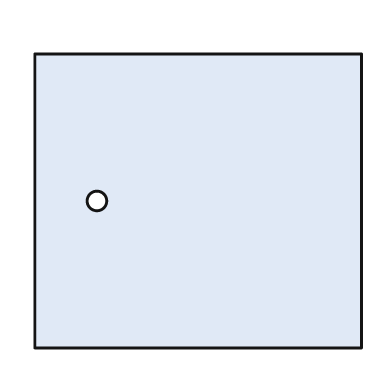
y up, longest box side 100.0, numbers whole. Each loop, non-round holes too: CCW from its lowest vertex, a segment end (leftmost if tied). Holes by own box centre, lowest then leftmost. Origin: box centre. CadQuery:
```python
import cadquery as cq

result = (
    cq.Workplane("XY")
    .moveTo(-50.0, -45.0)
    .lineTo(50.0, -45.0)
    .lineTo(50.0, 45.0)
    .lineTo(-50.0, 45.0)
    .close()
    .moveTo(-31.0, 0.0)
    .circle(3.0)
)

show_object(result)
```